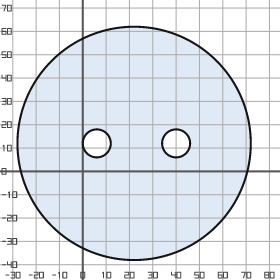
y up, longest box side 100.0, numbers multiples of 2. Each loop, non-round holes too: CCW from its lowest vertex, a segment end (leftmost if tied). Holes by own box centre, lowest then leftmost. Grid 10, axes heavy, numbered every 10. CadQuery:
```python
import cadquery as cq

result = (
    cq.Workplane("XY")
    .moveTo(22.0, 12.0)
    .circle(50.0)
    .moveTo(6.0, 12.0)
    .circle(6.0)
    .moveTo(40.0, 12.0)
    .circle(6.0)
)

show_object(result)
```